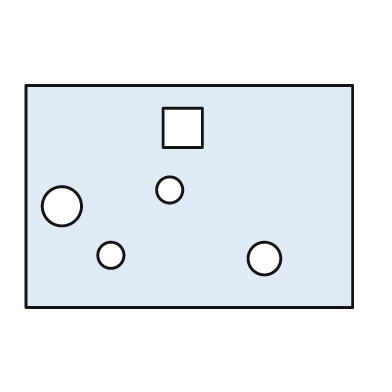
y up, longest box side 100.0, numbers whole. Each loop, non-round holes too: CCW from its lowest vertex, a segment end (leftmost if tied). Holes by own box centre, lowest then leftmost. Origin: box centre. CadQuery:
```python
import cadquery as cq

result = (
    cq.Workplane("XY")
    .moveTo(-50.0, -34.0)
    .lineTo(50.0, -34.0)
    .lineTo(50.0, 34.0)
    .lineTo(-50.0, 34.0)
    .close()
    .moveTo(23.0, -19.0)
    .circle(5.0)
    .moveTo(-24.0, -18.0)
    .circle(4.0)
    .moveTo(-39.0, -3.0)
    .circle(6.0)
    .moveTo(-6.0, 2.0)
    .circle(4.0)
    .moveTo(-8.0, 15.0)
    .lineTo(4.0, 15.0)
    .lineTo(4.0, 27.0)
    .lineTo(-8.0, 27.0)
    .close()
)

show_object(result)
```